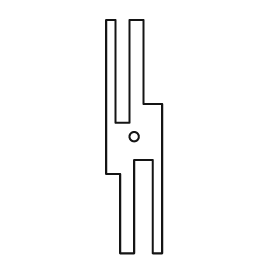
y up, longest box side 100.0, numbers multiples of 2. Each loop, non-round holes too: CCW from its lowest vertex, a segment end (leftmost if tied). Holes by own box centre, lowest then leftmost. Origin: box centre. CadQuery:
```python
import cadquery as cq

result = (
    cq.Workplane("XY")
    .moveTo(-6.0, -50.0)
    .lineTo(0.0, -50.0)
    .lineTo(0.0, -10.0)
    .lineTo(8.0, -10.0)
    .lineTo(8.0, -50.0)
    .lineTo(12.0, -50.0)
    .lineTo(12.0, 14.0)
    .lineTo(4.0, 14.0)
    .lineTo(4.0, 50.0)
    .lineTo(-2.0, 50.0)
    .lineTo(-2.0, 6.0)
    .lineTo(-8.0, 6.0)
    .lineTo(-8.0, 50.0)
    .lineTo(-12.0, 50.0)
    .lineTo(-12.0, -16.0)
    .lineTo(-6.0, -16.0)
    .close()
    .moveTo(0.0, 0.0)
    .circle(2.0)
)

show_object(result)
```